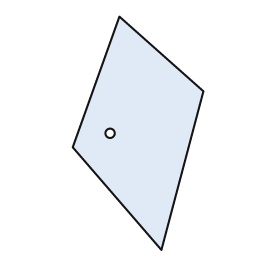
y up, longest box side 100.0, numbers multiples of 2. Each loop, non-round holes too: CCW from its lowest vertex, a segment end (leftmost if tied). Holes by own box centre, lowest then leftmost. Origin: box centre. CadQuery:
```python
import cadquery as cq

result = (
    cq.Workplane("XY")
    .moveTo(10.0, -50.0)
    .lineTo(28.0, 18.0)
    .lineTo(-8.0, 50.0)
    .lineTo(-28.0, -6.0)
    .close()
    .moveTo(-12.0, 0.0)
    .circle(2.0)
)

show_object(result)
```